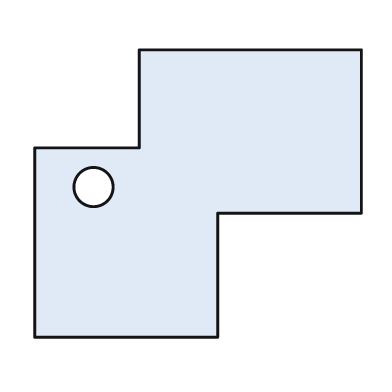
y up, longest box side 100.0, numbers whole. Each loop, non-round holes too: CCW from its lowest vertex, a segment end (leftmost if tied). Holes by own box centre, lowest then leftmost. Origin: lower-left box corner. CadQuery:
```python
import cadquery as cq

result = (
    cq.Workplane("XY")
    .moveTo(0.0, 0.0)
    .lineTo(56.0, 0.0)
    .lineTo(56.0, 38.0)
    .lineTo(100.0, 38.0)
    .lineTo(100.0, 88.0)
    .lineTo(32.0, 88.0)
    .lineTo(32.0, 58.0)
    .lineTo(0.0, 58.0)
    .close()
    .moveTo(18.0, 46.0)
    .circle(6.0)
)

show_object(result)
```